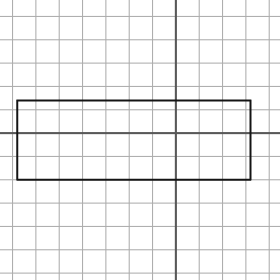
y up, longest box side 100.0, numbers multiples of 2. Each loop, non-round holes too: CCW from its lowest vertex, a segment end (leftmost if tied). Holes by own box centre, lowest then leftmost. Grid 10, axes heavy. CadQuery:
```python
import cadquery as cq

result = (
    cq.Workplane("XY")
    .moveTo(-68.0, -20.0)
    .lineTo(32.0, -20.0)
    .lineTo(32.0, 14.0)
    .lineTo(-68.0, 14.0)
    .close()
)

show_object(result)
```